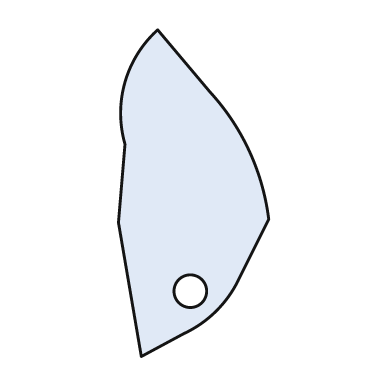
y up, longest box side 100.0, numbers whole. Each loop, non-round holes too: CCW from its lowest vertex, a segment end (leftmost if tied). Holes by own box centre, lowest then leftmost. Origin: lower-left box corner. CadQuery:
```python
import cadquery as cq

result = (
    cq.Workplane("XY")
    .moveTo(7.0, 0.0)
    .lineTo(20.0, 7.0)
    .threePointArc((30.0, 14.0), (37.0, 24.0))
    .lineTo(46.0, 42.0)
    .threePointArc((40.0, 63.0), (28.0, 81.0))
    .lineTo(12.0, 100.0)
    .threePointArc((2.0, 84.0), (2.0, 65.0))
    .lineTo(0.0, 41.0)
    .close()
    .moveTo(22.0, 20.0)
    .circle(5.0)
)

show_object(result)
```